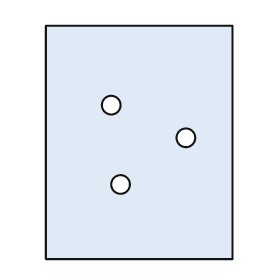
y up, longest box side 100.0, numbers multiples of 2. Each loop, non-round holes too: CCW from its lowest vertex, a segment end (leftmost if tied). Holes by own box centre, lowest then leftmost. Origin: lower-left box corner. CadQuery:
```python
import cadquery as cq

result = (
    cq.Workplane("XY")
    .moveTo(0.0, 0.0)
    .lineTo(80.0, 0.0)
    .lineTo(80.0, 100.0)
    .lineTo(0.0, 100.0)
    .close()
    .moveTo(32.0, 32.0)
    .circle(4.0)
    .moveTo(60.0, 52.0)
    .circle(4.0)
    .moveTo(28.0, 66.0)
    .circle(4.0)
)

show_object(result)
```